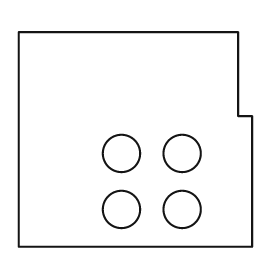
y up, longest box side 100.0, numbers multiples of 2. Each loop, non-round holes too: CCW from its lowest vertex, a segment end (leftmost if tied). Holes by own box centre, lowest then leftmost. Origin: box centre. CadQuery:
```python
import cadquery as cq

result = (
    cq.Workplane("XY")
    .moveTo(-50.0, -46.0)
    .lineTo(50.0, -46.0)
    .lineTo(50.0, 10.0)
    .lineTo(44.0, 10.0)
    .lineTo(44.0, 46.0)
    .lineTo(-50.0, 46.0)
    .close()
    .moveTo(-6.0, -30.0)
    .circle(8.0)
    .moveTo(20.0, -30.0)
    .circle(8.0)
    .moveTo(-6.0, -6.0)
    .circle(8.0)
    .moveTo(20.0, -6.0)
    .circle(8.0)
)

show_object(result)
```